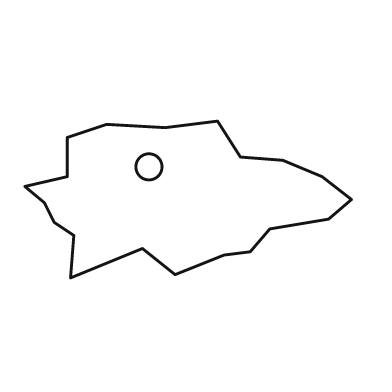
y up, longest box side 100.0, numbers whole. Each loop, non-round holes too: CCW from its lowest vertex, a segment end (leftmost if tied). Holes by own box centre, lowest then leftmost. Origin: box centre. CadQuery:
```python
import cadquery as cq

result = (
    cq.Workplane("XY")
    .moveTo(-36.0, -24.0)
    .lineTo(-14.0, -15.0)
    .lineTo(-4.0, -23.0)
    .lineTo(11.0, -17.0)
    .lineTo(19.0, -16.0)
    .lineTo(25.0, -9.0)
    .lineTo(43.0, -6.0)
    .lineTo(50.0, 0.0)
    .lineTo(41.0, 7.0)
    .lineTo(29.0, 12.0)
    .lineTo(16.0, 13.0)
    .lineTo(9.0, 24.0)
    .lineTo(-7.0, 22.0)
    .lineTo(-25.0, 23.0)
    .lineTo(-37.0, 19.0)
    .lineTo(-37.0, 7.0)
    .lineTo(-50.0, 4.0)
    .lineTo(-44.0, -1.0)
    .lineTo(-41.0, -7.0)
    .lineTo(-35.0, -11.0)
    .close()
    .moveTo(-12.0, 10.0)
    .circle(4.0)
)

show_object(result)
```